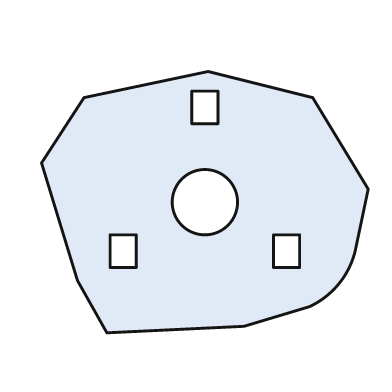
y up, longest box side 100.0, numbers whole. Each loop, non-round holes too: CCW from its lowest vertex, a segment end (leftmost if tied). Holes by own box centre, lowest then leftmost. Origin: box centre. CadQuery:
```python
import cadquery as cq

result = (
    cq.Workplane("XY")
    .moveTo(-30.0, -40.0)
    .lineTo(12.0, -38.0)
    .lineTo(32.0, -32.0)
    .threePointArc((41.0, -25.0), (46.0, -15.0))
    .lineTo(50.0, 4.0)
    .lineTo(33.0, 32.0)
    .lineTo(1.0, 40.0)
    .lineTo(-37.0, 32.0)
    .lineTo(-50.0, 12.0)
    .lineTo(-39.0, -24.0)
    .close()
    .moveTo(-29.0, -20.0)
    .lineTo(-21.0, -20.0)
    .lineTo(-21.0, -10.0)
    .lineTo(-29.0, -10.0)
    .close()
    .moveTo(21.0, -20.0)
    .lineTo(29.0, -20.0)
    .lineTo(29.0, -10.0)
    .lineTo(21.0, -10.0)
    .close()
    .moveTo(0.0, 0.0)
    .circle(10.0)
    .moveTo(-4.0, 24.0)
    .lineTo(4.0, 24.0)
    .lineTo(4.0, 34.0)
    .lineTo(-4.0, 34.0)
    .close()
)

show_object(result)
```